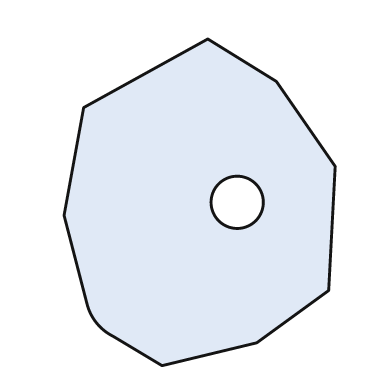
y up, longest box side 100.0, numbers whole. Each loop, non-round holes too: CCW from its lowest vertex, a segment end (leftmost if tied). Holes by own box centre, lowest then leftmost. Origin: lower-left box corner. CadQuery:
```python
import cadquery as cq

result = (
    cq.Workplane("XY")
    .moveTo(30.0, 0.0)
    .lineTo(59.0, 7.0)
    .lineTo(81.0, 23.0)
    .lineTo(83.0, 61.0)
    .lineTo(65.0, 87.0)
    .lineTo(44.0, 100.0)
    .lineTo(6.0, 79.0)
    .lineTo(0.0, 46.0)
    .lineTo(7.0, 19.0)
    .threePointArc((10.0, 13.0), (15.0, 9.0))
    .close()
    .moveTo(53.0, 50.0)
    .circle(8.0)
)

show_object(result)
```